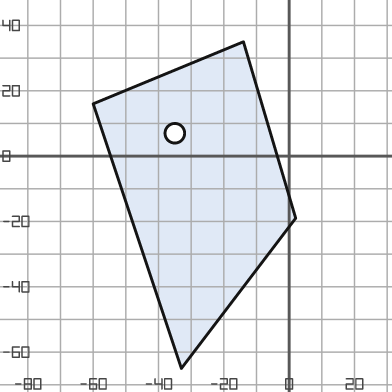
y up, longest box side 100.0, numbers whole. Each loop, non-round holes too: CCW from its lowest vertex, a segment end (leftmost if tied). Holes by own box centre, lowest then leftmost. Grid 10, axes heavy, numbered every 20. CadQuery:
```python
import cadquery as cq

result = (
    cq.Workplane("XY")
    .moveTo(-33.0, -65.0)
    .lineTo(2.0, -19.0)
    .lineTo(-14.0, 35.0)
    .lineTo(-60.0, 16.0)
    .close()
    .moveTo(-35.0, 7.0)
    .circle(3.0)
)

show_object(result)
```